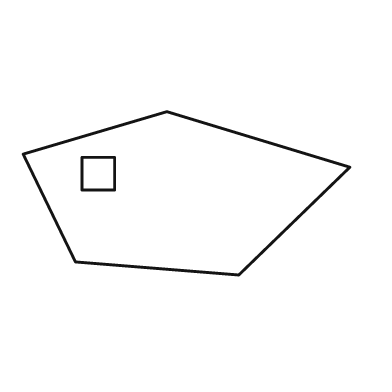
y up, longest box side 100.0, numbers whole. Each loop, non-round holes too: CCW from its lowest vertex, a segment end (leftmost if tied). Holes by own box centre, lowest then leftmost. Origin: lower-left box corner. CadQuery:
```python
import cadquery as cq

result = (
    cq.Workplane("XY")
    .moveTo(66.0, 0.0)
    .lineTo(100.0, 33.0)
    .lineTo(44.0, 50.0)
    .lineTo(0.0, 37.0)
    .lineTo(16.0, 4.0)
    .close()
    .moveTo(18.0, 26.0)
    .lineTo(28.0, 26.0)
    .lineTo(28.0, 36.0)
    .lineTo(18.0, 36.0)
    .close()
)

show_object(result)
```